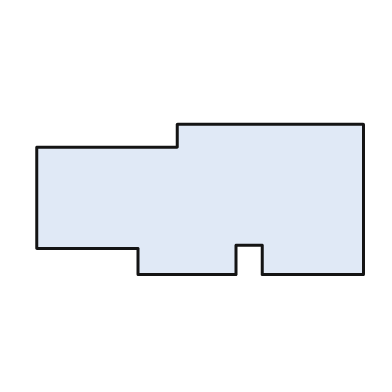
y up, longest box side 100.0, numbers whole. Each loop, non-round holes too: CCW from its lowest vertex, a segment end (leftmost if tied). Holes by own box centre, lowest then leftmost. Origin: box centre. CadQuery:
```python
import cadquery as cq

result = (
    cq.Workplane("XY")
    .moveTo(-19.0, -23.0)
    .lineTo(11.0, -23.0)
    .lineTo(11.0, -14.0)
    .lineTo(19.0, -14.0)
    .lineTo(19.0, -23.0)
    .lineTo(50.0, -23.0)
    .lineTo(50.0, 23.0)
    .lineTo(-7.0, 23.0)
    .lineTo(-7.0, 16.0)
    .lineTo(-50.0, 16.0)
    .lineTo(-50.0, -15.0)
    .lineTo(-19.0, -15.0)
    .close()
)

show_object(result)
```